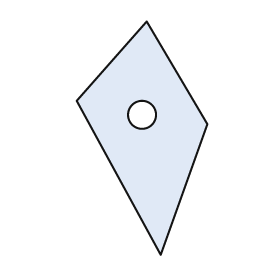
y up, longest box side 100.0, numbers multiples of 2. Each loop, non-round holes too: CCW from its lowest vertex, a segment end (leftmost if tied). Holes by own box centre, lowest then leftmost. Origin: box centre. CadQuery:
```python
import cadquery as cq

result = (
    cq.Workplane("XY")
    .moveTo(8.0, -50.0)
    .lineTo(28.0, 6.0)
    .lineTo(2.0, 50.0)
    .lineTo(-28.0, 16.0)
    .close()
    .moveTo(0.0, 10.0)
    .circle(6.0)
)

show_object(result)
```